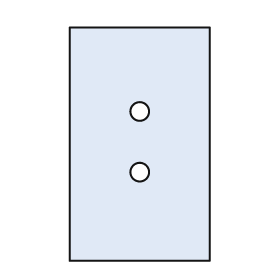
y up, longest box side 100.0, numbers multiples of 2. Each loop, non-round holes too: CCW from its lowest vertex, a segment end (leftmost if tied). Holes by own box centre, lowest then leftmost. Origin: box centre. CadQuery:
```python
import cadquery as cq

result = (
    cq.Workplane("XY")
    .moveTo(-30.0, -50.0)
    .lineTo(30.0, -50.0)
    .lineTo(30.0, 50.0)
    .lineTo(-30.0, 50.0)
    .close()
    .moveTo(0.0, -12.0)
    .circle(4.0)
    .moveTo(0.0, 14.0)
    .circle(4.0)
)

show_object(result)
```